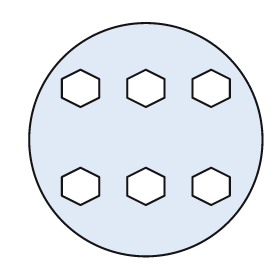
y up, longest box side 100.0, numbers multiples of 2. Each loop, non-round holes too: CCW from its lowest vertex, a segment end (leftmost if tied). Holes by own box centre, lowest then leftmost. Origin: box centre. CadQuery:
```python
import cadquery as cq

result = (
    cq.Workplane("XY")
    .moveTo(0.0, 0.0)
    .circle(50.0)
    .moveTo(-28.0, -28.0)
    .lineTo(-20.0, -24.0)
    .lineTo(-20.0, -16.0)
    .lineTo(-28.0, -12.0)
    .lineTo(-36.0, -16.0)
    .lineTo(-36.0, -24.0)
    .close()
    .moveTo(0.0, -28.0)
    .lineTo(8.0, -24.0)
    .lineTo(8.0, -16.0)
    .lineTo(0.0, -12.0)
    .lineTo(-8.0, -16.0)
    .lineTo(-8.0, -24.0)
    .close()
    .moveTo(28.0, -28.0)
    .lineTo(36.0, -24.0)
    .lineTo(36.0, -16.0)
    .lineTo(28.0, -12.0)
    .lineTo(20.0, -16.0)
    .lineTo(20.0, -24.0)
    .close()
    .moveTo(-28.0, 14.0)
    .lineTo(-20.0, 18.0)
    .lineTo(-20.0, 26.0)
    .lineTo(-28.0, 30.0)
    .lineTo(-36.0, 26.0)
    .lineTo(-36.0, 18.0)
    .close()
    .moveTo(0.0, 14.0)
    .lineTo(8.0, 18.0)
    .lineTo(8.0, 26.0)
    .lineTo(0.0, 30.0)
    .lineTo(-8.0, 26.0)
    .lineTo(-8.0, 18.0)
    .close()
    .moveTo(28.0, 14.0)
    .lineTo(36.0, 18.0)
    .lineTo(36.0, 26.0)
    .lineTo(28.0, 30.0)
    .lineTo(20.0, 26.0)
    .lineTo(20.0, 18.0)
    .close()
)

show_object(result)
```